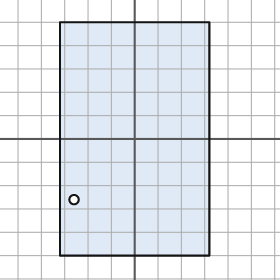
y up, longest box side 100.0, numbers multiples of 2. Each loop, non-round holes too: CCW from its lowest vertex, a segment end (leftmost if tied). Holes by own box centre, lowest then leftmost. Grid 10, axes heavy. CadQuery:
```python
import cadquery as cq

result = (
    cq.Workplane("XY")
    .moveTo(-32.0, -50.0)
    .lineTo(32.0, -50.0)
    .lineTo(32.0, 50.0)
    .lineTo(-32.0, 50.0)
    .close()
    .moveTo(-26.0, -26.0)
    .circle(2.0)
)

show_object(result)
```